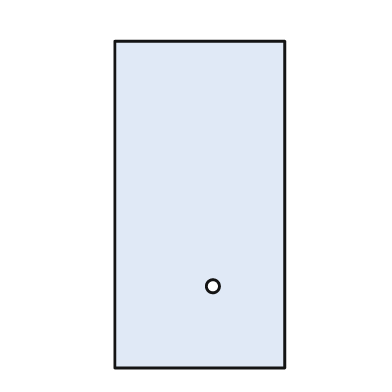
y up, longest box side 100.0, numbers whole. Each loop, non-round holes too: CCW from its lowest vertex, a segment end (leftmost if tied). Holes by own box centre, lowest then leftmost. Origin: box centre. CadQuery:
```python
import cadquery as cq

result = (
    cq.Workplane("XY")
    .moveTo(-26.0, -50.0)
    .lineTo(26.0, -50.0)
    .lineTo(26.0, 50.0)
    .lineTo(-26.0, 50.0)
    .close()
    .moveTo(4.0, -25.0)
    .circle(2.0)
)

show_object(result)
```